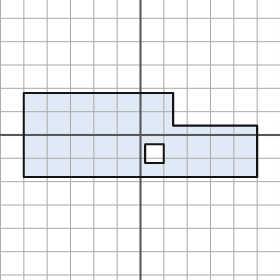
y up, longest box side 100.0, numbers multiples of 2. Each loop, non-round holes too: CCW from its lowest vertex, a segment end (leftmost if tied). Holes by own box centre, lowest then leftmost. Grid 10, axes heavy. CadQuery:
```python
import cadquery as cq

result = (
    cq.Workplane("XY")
    .moveTo(-50.0, -18.0)
    .lineTo(50.0, -18.0)
    .lineTo(50.0, 4.0)
    .lineTo(14.0, 4.0)
    .lineTo(14.0, 18.0)
    .lineTo(-50.0, 18.0)
    .close()
    .moveTo(2.0, -12.0)
    .lineTo(10.0, -12.0)
    .lineTo(10.0, -4.0)
    .lineTo(2.0, -4.0)
    .close()
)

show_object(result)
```